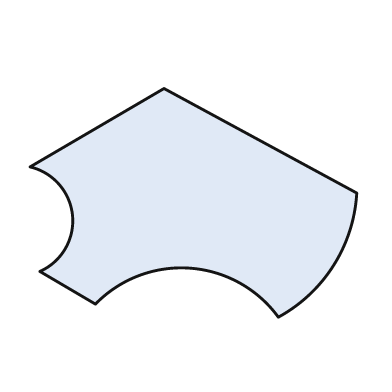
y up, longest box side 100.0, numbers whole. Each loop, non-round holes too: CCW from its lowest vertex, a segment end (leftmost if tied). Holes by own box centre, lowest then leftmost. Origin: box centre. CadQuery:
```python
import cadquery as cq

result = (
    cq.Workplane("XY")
    .moveTo(26.0, -35.0)
    .threePointArc((43.0, -19.0), (50.0, 3.0))
    .lineTo(-9.0, 35.0)
    .lineTo(-50.0, 11.0)
    .threePointArc((-37.0, -4.0), (-47.0, -21.0))
    .lineTo(-30.0, -31.0)
    .threePointArc((-1.0, -20.0), (26.0, -35.0))
    .close()
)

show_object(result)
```